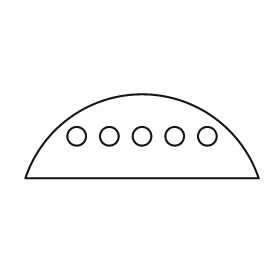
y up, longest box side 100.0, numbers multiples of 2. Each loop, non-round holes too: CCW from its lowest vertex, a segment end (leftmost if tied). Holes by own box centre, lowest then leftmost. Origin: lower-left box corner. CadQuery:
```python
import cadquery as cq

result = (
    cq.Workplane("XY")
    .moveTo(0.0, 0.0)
    .lineTo(100.0, 0.0)
    .threePointArc((50.0, 36.0), (0.0, 0.0))
    .close()
    .moveTo(22.0, 18.0)
    .circle(4.0)
    .moveTo(36.0, 18.0)
    .circle(4.0)
    .moveTo(50.0, 18.0)
    .circle(4.0)
    .moveTo(64.0, 18.0)
    .circle(4.0)
    .moveTo(78.0, 18.0)
    .circle(4.0)
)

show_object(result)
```